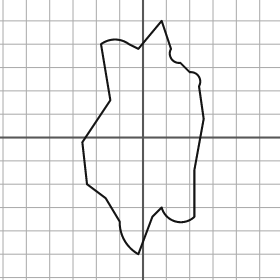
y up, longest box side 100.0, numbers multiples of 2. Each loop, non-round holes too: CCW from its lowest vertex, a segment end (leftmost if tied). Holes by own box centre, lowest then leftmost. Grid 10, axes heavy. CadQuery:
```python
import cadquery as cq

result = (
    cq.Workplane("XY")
    .moveTo(-2.0, -50.0)
    .lineTo(4.0, -34.0)
    .lineTo(8.0, -30.0)
    .threePointArc((14.0, -36.0), (22.0, -34.0))
    .lineTo(22.0, -14.0)
    .lineTo(26.0, 8.0)
    .lineTo(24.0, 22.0)
    .threePointArc((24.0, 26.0), (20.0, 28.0))
    .lineTo(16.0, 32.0)
    .threePointArc((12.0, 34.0), (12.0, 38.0))
    .lineTo(8.0, 50.0)
    .lineTo(-2.0, 38.0)
    .lineTo(-6.0, 40.0)
    .threePointArc((-12.0, 42.0), (-18.0, 40.0))
    .lineTo(-14.0, 16.0)
    .lineTo(-26.0, -2.0)
    .lineTo(-24.0, -20.0)
    .lineTo(-16.0, -26.0)
    .lineTo(-10.0, -36.0)
    .threePointArc((-8.0, -44.0), (-2.0, -50.0))
    .close()
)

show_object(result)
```